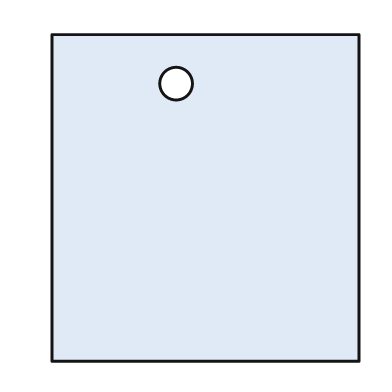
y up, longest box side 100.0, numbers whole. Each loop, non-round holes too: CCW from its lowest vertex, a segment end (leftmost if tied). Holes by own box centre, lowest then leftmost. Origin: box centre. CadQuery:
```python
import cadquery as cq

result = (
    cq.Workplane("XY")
    .moveTo(-47.0, -50.0)
    .lineTo(47.0, -50.0)
    .lineTo(47.0, 50.0)
    .lineTo(-47.0, 50.0)
    .close()
    .moveTo(-9.0, 35.0)
    .circle(5.0)
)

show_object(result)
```